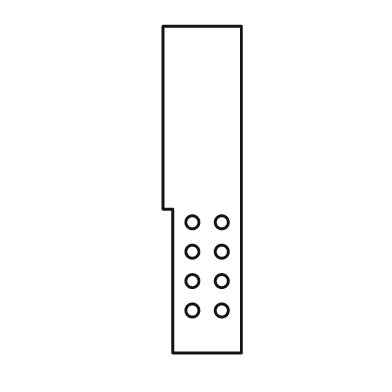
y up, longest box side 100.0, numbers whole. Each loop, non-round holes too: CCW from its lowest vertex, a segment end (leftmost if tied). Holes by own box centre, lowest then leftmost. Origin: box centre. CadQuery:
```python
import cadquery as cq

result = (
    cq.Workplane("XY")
    .moveTo(-9.0, -50.0)
    .lineTo(12.0, -50.0)
    .lineTo(12.0, 50.0)
    .lineTo(-12.0, 50.0)
    .lineTo(-12.0, -6.0)
    .lineTo(-9.0, -6.0)
    .close()
    .moveTo(-3.0, -37.0)
    .circle(2.0)
    .moveTo(6.0, -37.0)
    .circle(2.0)
    .moveTo(-3.0, -28.0)
    .circle(2.0)
    .moveTo(6.0, -28.0)
    .circle(2.0)
    .moveTo(-3.0, -19.0)
    .circle(2.0)
    .moveTo(6.0, -19.0)
    .circle(2.0)
    .moveTo(-3.0, -10.0)
    .circle(2.0)
    .moveTo(6.0, -10.0)
    .circle(2.0)
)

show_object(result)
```